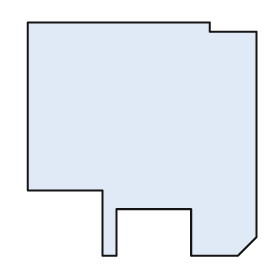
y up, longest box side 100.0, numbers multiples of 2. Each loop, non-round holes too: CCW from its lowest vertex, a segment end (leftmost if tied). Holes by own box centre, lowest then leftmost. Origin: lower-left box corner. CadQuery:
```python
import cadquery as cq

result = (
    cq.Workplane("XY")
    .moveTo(32.0, 0.0)
    .lineTo(38.0, 0.0)
    .lineTo(38.0, 20.0)
    .lineTo(70.0, 20.0)
    .lineTo(70.0, 0.0)
    .lineTo(90.0, 0.0)
    .lineTo(98.0, 8.0)
    .lineTo(98.0, 96.0)
    .lineTo(78.0, 96.0)
    .lineTo(78.0, 100.0)
    .lineTo(0.0, 100.0)
    .lineTo(0.0, 28.0)
    .lineTo(32.0, 28.0)
    .close()
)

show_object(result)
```